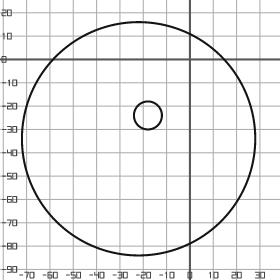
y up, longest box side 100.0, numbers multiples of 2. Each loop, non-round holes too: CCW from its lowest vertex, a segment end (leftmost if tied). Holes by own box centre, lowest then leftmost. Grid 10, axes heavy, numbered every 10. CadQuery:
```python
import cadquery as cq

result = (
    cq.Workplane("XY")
    .moveTo(-22.0, -34.0)
    .circle(50.0)
    .moveTo(-18.0, -24.0)
    .circle(6.0)
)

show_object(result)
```